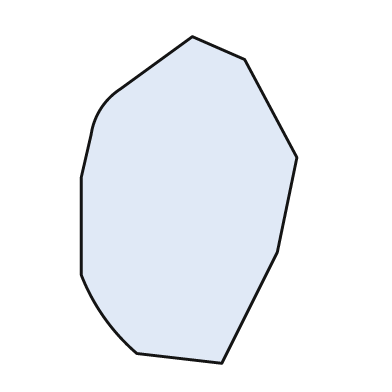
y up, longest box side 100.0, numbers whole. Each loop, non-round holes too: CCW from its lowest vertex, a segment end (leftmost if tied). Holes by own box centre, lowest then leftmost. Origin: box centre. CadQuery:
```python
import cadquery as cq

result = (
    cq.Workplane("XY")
    .moveTo(10.0, -50.0)
    .lineTo(27.0, -16.0)
    .lineTo(33.0, 13.0)
    .lineTo(17.0, 43.0)
    .lineTo(1.0, 50.0)
    .lineTo(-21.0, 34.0)
    .threePointArc((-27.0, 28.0), (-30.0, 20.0))
    .lineTo(-33.0, 7.0)
    .lineTo(-33.0, -23.0)
    .threePointArc((-26.0, -36.0), (-16.0, -47.0))
    .close()
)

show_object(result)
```